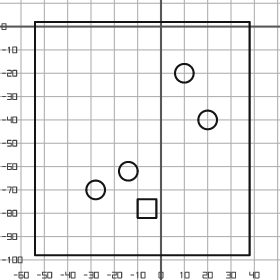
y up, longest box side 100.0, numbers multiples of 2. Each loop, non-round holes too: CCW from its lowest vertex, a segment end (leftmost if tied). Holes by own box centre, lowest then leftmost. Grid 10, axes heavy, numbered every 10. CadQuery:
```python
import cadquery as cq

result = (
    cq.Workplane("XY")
    .moveTo(-54.0, -98.0)
    .lineTo(38.0, -98.0)
    .lineTo(38.0, 2.0)
    .lineTo(-54.0, 2.0)
    .close()
    .moveTo(-10.0, -82.0)
    .lineTo(-2.0, -82.0)
    .lineTo(-2.0, -74.0)
    .lineTo(-10.0, -74.0)
    .close()
    .moveTo(-28.0, -70.0)
    .circle(4.0)
    .moveTo(-14.0, -62.0)
    .circle(4.0)
    .moveTo(20.0, -40.0)
    .circle(4.0)
    .moveTo(10.0, -20.0)
    .circle(4.0)
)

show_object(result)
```